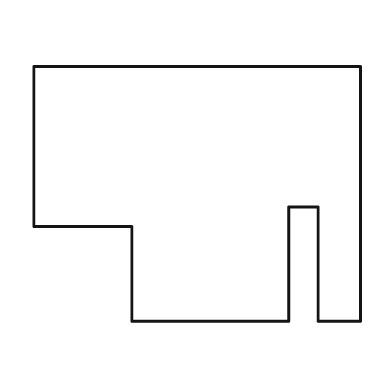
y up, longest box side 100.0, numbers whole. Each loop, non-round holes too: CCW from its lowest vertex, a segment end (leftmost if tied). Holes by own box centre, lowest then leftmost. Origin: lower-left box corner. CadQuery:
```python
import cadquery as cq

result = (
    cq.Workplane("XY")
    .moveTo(30.0, 0.0)
    .lineTo(78.0, 0.0)
    .lineTo(78.0, 35.0)
    .lineTo(87.0, 35.0)
    .lineTo(87.0, 0.0)
    .lineTo(100.0, 0.0)
    .lineTo(100.0, 78.0)
    .lineTo(0.0, 78.0)
    .lineTo(0.0, 29.0)
    .lineTo(30.0, 29.0)
    .close()
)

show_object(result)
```